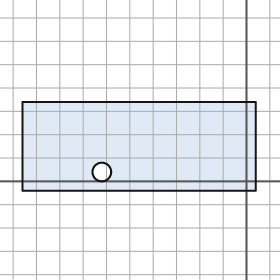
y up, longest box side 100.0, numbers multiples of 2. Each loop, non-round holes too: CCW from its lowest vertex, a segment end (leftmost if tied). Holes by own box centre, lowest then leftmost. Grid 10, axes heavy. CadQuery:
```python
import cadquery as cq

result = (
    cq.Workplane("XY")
    .moveTo(-96.0, -4.0)
    .lineTo(4.0, -4.0)
    .lineTo(4.0, 34.0)
    .lineTo(-96.0, 34.0)
    .close()
    .moveTo(-62.0, 4.0)
    .circle(4.0)
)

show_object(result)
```